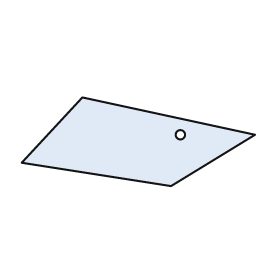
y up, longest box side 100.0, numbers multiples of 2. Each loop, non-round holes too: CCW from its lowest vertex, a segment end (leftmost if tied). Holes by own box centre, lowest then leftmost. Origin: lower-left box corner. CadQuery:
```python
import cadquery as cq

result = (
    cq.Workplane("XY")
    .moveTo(64.0, 0.0)
    .lineTo(100.0, 22.0)
    .lineTo(26.0, 38.0)
    .lineTo(0.0, 10.0)
    .close()
    .moveTo(68.0, 22.0)
    .circle(2.0)
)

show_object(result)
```